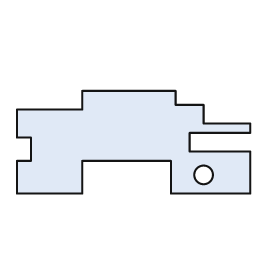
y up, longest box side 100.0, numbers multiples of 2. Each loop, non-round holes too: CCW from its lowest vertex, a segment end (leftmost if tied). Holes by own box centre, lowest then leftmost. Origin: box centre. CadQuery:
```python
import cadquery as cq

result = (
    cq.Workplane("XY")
    .moveTo(-50.0, -22.0)
    .lineTo(-22.0, -22.0)
    .lineTo(-22.0, -8.0)
    .lineTo(16.0, -8.0)
    .lineTo(16.0, -22.0)
    .lineTo(50.0, -22.0)
    .lineTo(50.0, -4.0)
    .lineTo(24.0, -4.0)
    .lineTo(24.0, 4.0)
    .lineTo(50.0, 4.0)
    .lineTo(50.0, 8.0)
    .lineTo(30.0, 8.0)
    .lineTo(30.0, 16.0)
    .lineTo(18.0, 16.0)
    .lineTo(18.0, 22.0)
    .lineTo(-22.0, 22.0)
    .lineTo(-22.0, 14.0)
    .lineTo(-50.0, 14.0)
    .lineTo(-50.0, 2.0)
    .lineTo(-44.0, 2.0)
    .lineTo(-44.0, -8.0)
    .lineTo(-50.0, -8.0)
    .close()
    .moveTo(30.0, -14.0)
    .circle(4.0)
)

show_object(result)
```